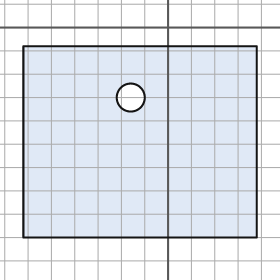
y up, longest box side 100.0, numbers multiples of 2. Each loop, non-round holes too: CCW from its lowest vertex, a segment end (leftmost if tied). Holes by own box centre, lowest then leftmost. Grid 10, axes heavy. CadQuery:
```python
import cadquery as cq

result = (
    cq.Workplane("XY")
    .moveTo(-62.0, -90.0)
    .lineTo(38.0, -90.0)
    .lineTo(38.0, -8.0)
    .lineTo(-62.0, -8.0)
    .close()
    .moveTo(-16.0, -30.0)
    .circle(6.0)
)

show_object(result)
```